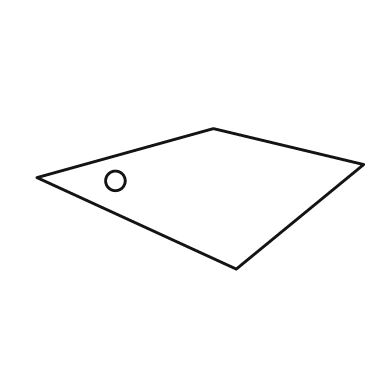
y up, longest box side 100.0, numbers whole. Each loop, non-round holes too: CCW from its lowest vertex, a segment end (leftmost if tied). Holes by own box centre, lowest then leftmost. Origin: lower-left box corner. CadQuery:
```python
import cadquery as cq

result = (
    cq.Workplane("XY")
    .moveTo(61.0, 0.0)
    .lineTo(100.0, 32.0)
    .lineTo(54.0, 43.0)
    .lineTo(0.0, 28.0)
    .close()
    .moveTo(24.0, 27.0)
    .circle(3.0)
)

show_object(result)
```